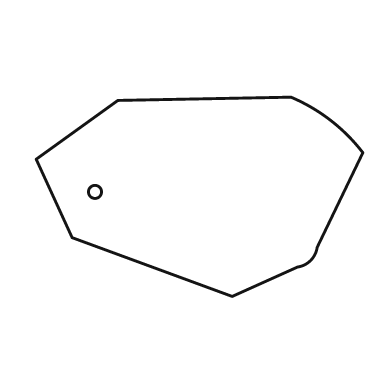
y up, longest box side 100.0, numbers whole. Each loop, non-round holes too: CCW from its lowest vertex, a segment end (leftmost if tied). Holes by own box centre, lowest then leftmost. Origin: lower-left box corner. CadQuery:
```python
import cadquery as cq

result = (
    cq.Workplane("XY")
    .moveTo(60.0, 0.0)
    .lineTo(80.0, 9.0)
    .threePointArc((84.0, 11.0), (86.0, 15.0))
    .lineTo(100.0, 44.0)
    .threePointArc((90.0, 54.0), (78.0, 61.0))
    .lineTo(25.0, 60.0)
    .lineTo(0.0, 42.0)
    .lineTo(11.0, 18.0)
    .close()
    .moveTo(18.0, 32.0)
    .circle(2.0)
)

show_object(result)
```